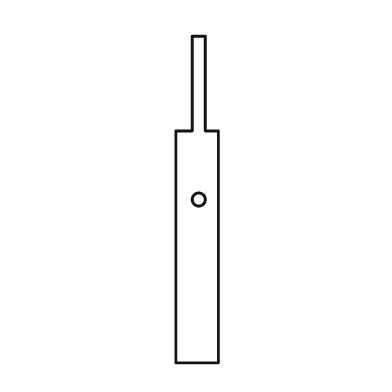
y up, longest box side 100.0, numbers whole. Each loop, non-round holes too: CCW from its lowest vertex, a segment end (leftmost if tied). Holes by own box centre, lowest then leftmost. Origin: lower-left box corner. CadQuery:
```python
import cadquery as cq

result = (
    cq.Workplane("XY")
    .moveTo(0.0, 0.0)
    .lineTo(13.0, 0.0)
    .lineTo(13.0, 71.0)
    .lineTo(9.0, 71.0)
    .lineTo(9.0, 100.0)
    .lineTo(5.0, 100.0)
    .lineTo(5.0, 71.0)
    .lineTo(0.0, 71.0)
    .close()
    .moveTo(7.0, 50.0)
    .circle(2.0)
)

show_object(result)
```